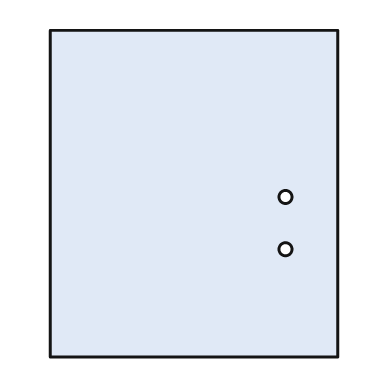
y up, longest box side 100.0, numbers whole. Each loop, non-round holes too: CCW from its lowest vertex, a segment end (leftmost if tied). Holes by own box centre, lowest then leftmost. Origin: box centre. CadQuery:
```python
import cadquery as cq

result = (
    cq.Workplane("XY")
    .moveTo(-44.0, -50.0)
    .lineTo(44.0, -50.0)
    .lineTo(44.0, 50.0)
    .lineTo(-44.0, 50.0)
    .close()
    .moveTo(28.0, -17.0)
    .circle(2.0)
    .moveTo(28.0, -1.0)
    .circle(2.0)
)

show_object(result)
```